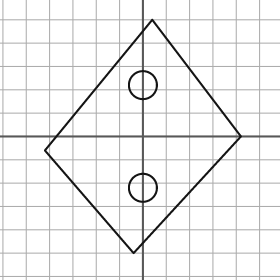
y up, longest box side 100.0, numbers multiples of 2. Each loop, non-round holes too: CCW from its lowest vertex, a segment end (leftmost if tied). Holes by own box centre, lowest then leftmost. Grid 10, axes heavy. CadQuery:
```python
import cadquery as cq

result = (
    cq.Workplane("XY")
    .moveTo(-4.0, -50.0)
    .lineTo(42.0, 0.0)
    .lineTo(4.0, 50.0)
    .lineTo(-42.0, -6.0)
    .close()
    .moveTo(0.0, -22.0)
    .circle(6.0)
    .moveTo(0.0, 22.0)
    .circle(6.0)
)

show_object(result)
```